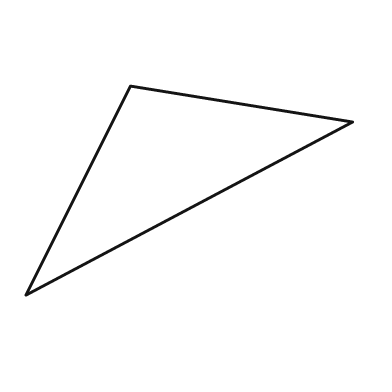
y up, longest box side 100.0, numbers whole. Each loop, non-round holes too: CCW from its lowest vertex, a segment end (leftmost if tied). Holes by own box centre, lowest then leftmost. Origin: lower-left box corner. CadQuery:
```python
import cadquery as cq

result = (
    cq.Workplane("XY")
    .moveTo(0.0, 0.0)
    .lineTo(100.0, 53.0)
    .lineTo(32.0, 64.0)
    .close()
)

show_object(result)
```